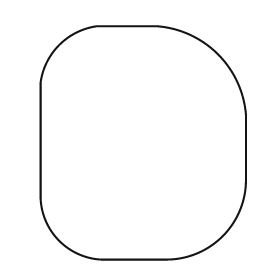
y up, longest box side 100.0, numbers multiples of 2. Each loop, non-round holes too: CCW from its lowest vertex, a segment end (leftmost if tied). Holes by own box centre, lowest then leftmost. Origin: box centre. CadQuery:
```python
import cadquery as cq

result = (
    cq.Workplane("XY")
    .moveTo(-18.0, -50.0)
    .lineTo(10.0, -50.0)
    .threePointArc((34.0, -40.0), (44.0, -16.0))
    .lineTo(44.0, 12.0)
    .threePointArc((32.0, 38.0), (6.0, 50.0))
    .lineTo(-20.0, 50.0)
    .threePointArc((-36.0, 42.0), (-44.0, 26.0))
    .lineTo(-44.0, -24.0)
    .threePointArc((-36.0, -42.0), (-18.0, -50.0))
    .close()
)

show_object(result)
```